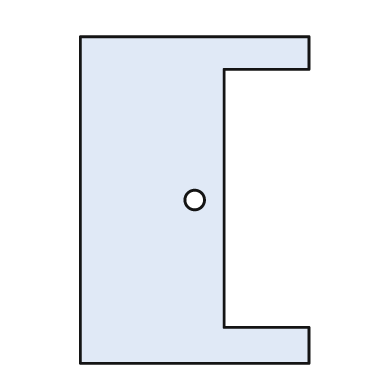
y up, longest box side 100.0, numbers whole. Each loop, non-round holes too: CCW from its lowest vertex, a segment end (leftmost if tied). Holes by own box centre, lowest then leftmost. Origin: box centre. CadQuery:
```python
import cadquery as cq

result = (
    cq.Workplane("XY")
    .moveTo(-35.0, -50.0)
    .lineTo(35.0, -50.0)
    .lineTo(35.0, -39.0)
    .lineTo(9.0, -39.0)
    .lineTo(9.0, 40.0)
    .lineTo(35.0, 40.0)
    .lineTo(35.0, 50.0)
    .lineTo(-35.0, 50.0)
    .close()
    .moveTo(0.0, 0.0)
    .circle(3.0)
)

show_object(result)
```